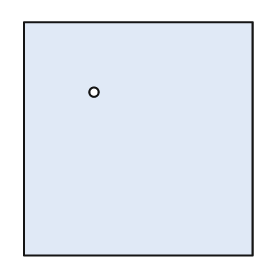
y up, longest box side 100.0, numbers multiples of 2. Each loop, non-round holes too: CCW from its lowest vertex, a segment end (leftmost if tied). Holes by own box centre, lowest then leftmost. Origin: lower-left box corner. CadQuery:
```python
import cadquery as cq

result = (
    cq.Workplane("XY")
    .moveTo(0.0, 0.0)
    .lineTo(98.0, 0.0)
    .lineTo(98.0, 100.0)
    .lineTo(0.0, 100.0)
    .close()
    .moveTo(30.0, 70.0)
    .circle(2.0)
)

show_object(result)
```